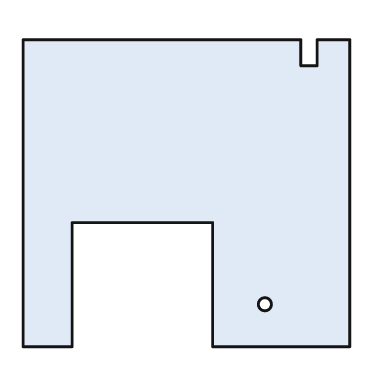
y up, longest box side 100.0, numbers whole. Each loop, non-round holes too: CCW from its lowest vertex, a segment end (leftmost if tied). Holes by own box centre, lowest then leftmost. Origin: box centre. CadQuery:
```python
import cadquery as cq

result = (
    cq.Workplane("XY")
    .moveTo(-50.0, -47.0)
    .lineTo(-35.0, -47.0)
    .lineTo(-35.0, -9.0)
    .lineTo(8.0, -9.0)
    .lineTo(8.0, -47.0)
    .lineTo(50.0, -47.0)
    .lineTo(50.0, 47.0)
    .lineTo(40.0, 47.0)
    .lineTo(40.0, 39.0)
    .lineTo(35.0, 39.0)
    .lineTo(35.0, 47.0)
    .lineTo(-50.0, 47.0)
    .close()
    .moveTo(24.0, -34.0)
    .circle(2.0)
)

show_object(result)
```